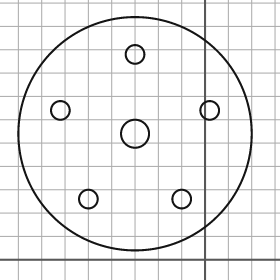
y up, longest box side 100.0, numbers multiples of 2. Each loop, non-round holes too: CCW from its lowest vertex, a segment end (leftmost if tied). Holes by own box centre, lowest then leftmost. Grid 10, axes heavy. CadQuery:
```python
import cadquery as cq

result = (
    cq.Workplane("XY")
    .moveTo(-30.0, 54.0)
    .circle(50.0)
    .moveTo(-50.0, 26.0)
    .circle(4.0)
    .moveTo(-10.0, 26.0)
    .circle(4.0)
    .moveTo(-30.0, 54.0)
    .circle(6.0)
    .moveTo(-62.0, 64.0)
    .circle(4.0)
    .moveTo(2.0, 64.0)
    .circle(4.0)
    .moveTo(-30.0, 88.0)
    .circle(4.0)
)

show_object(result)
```